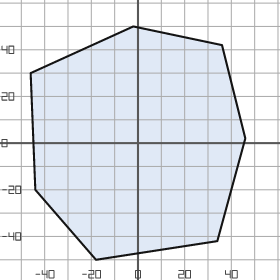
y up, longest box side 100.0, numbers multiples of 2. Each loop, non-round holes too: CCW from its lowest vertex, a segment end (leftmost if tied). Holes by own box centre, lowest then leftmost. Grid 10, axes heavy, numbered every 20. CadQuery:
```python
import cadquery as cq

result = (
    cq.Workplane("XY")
    .moveTo(-18.0, -50.0)
    .lineTo(34.0, -42.0)
    .lineTo(46.0, 2.0)
    .lineTo(36.0, 42.0)
    .lineTo(-2.0, 50.0)
    .lineTo(-46.0, 30.0)
    .lineTo(-44.0, -20.0)
    .close()
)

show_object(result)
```